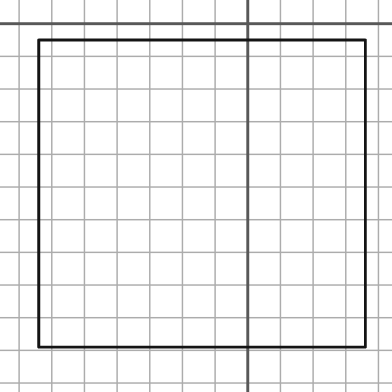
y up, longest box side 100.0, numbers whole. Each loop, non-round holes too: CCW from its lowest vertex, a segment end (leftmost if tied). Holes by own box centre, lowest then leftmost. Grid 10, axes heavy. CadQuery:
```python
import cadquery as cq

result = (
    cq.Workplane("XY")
    .moveTo(-64.0, -99.0)
    .lineTo(36.0, -99.0)
    .lineTo(36.0, -5.0)
    .lineTo(-64.0, -5.0)
    .close()
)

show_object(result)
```